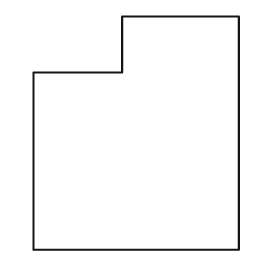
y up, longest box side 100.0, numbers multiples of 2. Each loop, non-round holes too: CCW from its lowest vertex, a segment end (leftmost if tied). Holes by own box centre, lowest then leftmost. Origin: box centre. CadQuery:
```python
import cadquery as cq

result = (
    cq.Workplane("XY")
    .moveTo(-44.0, -50.0)
    .lineTo(44.0, -50.0)
    .lineTo(44.0, 50.0)
    .lineTo(-6.0, 50.0)
    .lineTo(-6.0, 26.0)
    .lineTo(-44.0, 26.0)
    .close()
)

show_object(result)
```